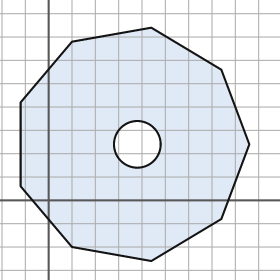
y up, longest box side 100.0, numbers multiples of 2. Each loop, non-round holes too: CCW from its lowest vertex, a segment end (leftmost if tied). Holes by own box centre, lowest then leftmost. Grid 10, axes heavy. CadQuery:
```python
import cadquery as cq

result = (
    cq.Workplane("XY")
    .moveTo(44.0, -26.0)
    .lineTo(74.0, -8.0)
    .lineTo(86.0, 24.0)
    .lineTo(74.0, 56.0)
    .lineTo(44.0, 74.0)
    .lineTo(10.0, 68.0)
    .lineTo(-12.0, 42.0)
    .lineTo(-12.0, 6.0)
    .lineTo(10.0, -20.0)
    .close()
    .moveTo(38.0, 24.0)
    .circle(10.0)
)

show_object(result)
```